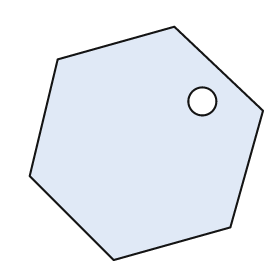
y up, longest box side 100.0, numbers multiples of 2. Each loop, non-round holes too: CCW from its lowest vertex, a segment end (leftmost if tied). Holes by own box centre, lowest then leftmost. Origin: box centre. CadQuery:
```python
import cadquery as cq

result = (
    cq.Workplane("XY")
    .moveTo(-14.0, -50.0)
    .lineTo(36.0, -36.0)
    .lineTo(50.0, 14.0)
    .lineTo(12.0, 50.0)
    .lineTo(-38.0, 36.0)
    .lineTo(-50.0, -14.0)
    .close()
    .moveTo(24.0, 18.0)
    .circle(6.0)
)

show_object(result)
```